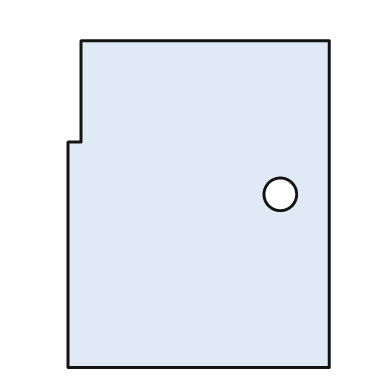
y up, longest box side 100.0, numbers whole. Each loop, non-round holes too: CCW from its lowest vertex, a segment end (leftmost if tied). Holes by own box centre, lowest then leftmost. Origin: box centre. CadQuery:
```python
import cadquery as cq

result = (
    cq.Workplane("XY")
    .moveTo(-40.0, -50.0)
    .lineTo(40.0, -50.0)
    .lineTo(40.0, 50.0)
    .lineTo(-36.0, 50.0)
    .lineTo(-36.0, 19.0)
    .lineTo(-40.0, 19.0)
    .close()
    .moveTo(25.0, 3.0)
    .circle(5.0)
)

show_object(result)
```